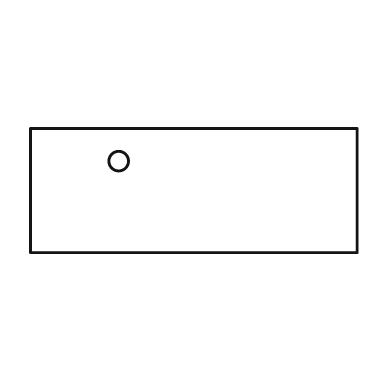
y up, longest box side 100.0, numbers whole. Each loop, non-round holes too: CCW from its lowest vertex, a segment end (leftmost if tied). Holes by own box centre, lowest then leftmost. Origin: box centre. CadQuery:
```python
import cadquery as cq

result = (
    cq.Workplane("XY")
    .moveTo(-50.0, -19.0)
    .lineTo(50.0, -19.0)
    .lineTo(50.0, 19.0)
    .lineTo(-50.0, 19.0)
    .close()
    .moveTo(-23.0, 9.0)
    .circle(3.0)
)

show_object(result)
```